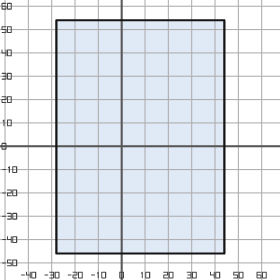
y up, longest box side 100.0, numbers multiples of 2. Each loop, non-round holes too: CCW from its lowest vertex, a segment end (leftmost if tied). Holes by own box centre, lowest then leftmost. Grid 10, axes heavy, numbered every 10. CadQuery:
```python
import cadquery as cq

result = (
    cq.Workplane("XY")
    .moveTo(-28.0, -46.0)
    .lineTo(44.0, -46.0)
    .lineTo(44.0, 54.0)
    .lineTo(-28.0, 54.0)
    .close()
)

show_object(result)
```